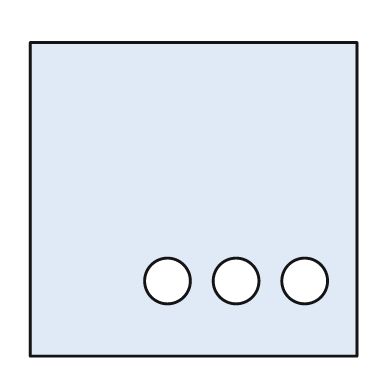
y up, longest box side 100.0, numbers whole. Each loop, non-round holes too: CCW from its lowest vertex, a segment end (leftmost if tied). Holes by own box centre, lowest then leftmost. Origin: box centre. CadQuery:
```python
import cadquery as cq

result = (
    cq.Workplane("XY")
    .moveTo(-50.0, -48.0)
    .lineTo(50.0, -48.0)
    .lineTo(50.0, 48.0)
    .lineTo(-50.0, 48.0)
    .close()
    .moveTo(-8.0, -25.0)
    .circle(7.0)
    .moveTo(13.0, -25.0)
    .circle(7.0)
    .moveTo(34.0, -25.0)
    .circle(7.0)
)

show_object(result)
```